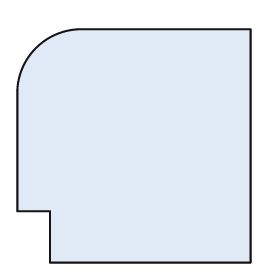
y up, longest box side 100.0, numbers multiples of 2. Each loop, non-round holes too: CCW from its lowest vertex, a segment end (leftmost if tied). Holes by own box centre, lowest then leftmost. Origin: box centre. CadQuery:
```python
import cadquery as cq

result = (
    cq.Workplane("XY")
    .moveTo(-36.0, -50.0)
    .lineTo(50.0, -50.0)
    .lineTo(50.0, 50.0)
    .lineTo(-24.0, 50.0)
    .threePointArc((-42.0, 42.0), (-50.0, 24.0))
    .lineTo(-50.0, -28.0)
    .lineTo(-36.0, -28.0)
    .close()
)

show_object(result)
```